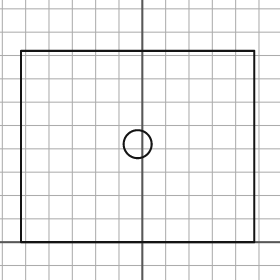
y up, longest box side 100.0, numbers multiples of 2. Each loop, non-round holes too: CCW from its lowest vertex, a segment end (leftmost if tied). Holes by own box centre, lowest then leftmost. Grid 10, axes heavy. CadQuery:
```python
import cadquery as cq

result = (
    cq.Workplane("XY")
    .moveTo(-52.0, 0.0)
    .lineTo(48.0, 0.0)
    .lineTo(48.0, 82.0)
    .lineTo(-52.0, 82.0)
    .close()
    .moveTo(-2.0, 42.0)
    .circle(6.0)
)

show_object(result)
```